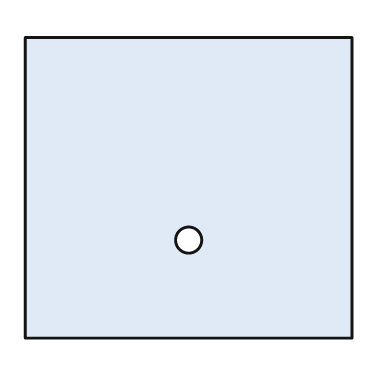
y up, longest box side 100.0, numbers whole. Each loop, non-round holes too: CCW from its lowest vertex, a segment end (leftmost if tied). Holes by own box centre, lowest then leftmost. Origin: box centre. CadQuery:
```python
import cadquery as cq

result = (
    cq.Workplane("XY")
    .moveTo(-50.0, -46.0)
    .lineTo(50.0, -46.0)
    .lineTo(50.0, 46.0)
    .lineTo(-50.0, 46.0)
    .close()
    .moveTo(0.0, -16.0)
    .circle(4.0)
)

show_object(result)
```